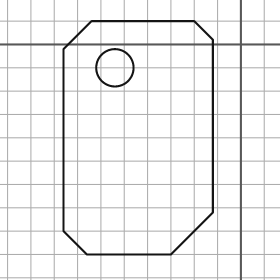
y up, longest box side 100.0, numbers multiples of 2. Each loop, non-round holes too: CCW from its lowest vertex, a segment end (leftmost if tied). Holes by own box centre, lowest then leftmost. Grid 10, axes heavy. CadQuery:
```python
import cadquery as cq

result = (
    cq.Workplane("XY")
    .moveTo(-66.0, -90.0)
    .lineTo(-30.0, -90.0)
    .lineTo(-12.0, -72.0)
    .lineTo(-12.0, 2.0)
    .lineTo(-20.0, 10.0)
    .lineTo(-64.0, 10.0)
    .lineTo(-76.0, -2.0)
    .lineTo(-76.0, -80.0)
    .close()
    .moveTo(-54.0, -10.0)
    .circle(8.0)
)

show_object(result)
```